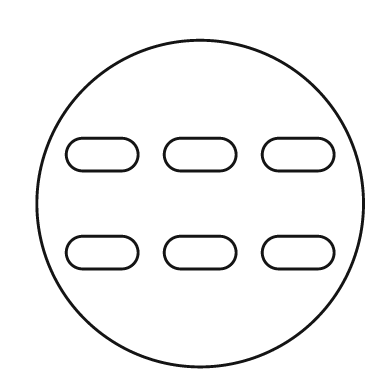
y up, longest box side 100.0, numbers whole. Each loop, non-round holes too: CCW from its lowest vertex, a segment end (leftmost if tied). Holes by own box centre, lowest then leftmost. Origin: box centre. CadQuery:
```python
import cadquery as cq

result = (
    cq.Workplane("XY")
    .moveTo(0.0, 0.0)
    .circle(50.0)
    .moveTo(-36.0, -20.0)
    .lineTo(-24.0, -20.0)
    .threePointArc((-19.0, -15.0), (-24.0, -10.0))
    .lineTo(-36.0, -10.0)
    .threePointArc((-41.0, -15.0), (-36.0, -20.0))
    .close()
    .moveTo(-6.0, -20.0)
    .lineTo(6.0, -20.0)
    .threePointArc((11.0, -15.0), (6.0, -10.0))
    .lineTo(-6.0, -10.0)
    .threePointArc((-11.0, -15.0), (-6.0, -20.0))
    .close()
    .moveTo(24.0, -20.0)
    .lineTo(36.0, -20.0)
    .threePointArc((41.0, -15.0), (36.0, -10.0))
    .lineTo(24.0, -10.0)
    .threePointArc((19.0, -15.0), (24.0, -20.0))
    .close()
    .moveTo(-36.0, 10.0)
    .lineTo(-24.0, 10.0)
    .threePointArc((-19.0, 15.0), (-24.0, 20.0))
    .lineTo(-36.0, 20.0)
    .threePointArc((-41.0, 15.0), (-36.0, 10.0))
    .close()
    .moveTo(-6.0, 10.0)
    .lineTo(6.0, 10.0)
    .threePointArc((11.0, 15.0), (6.0, 20.0))
    .lineTo(-6.0, 20.0)
    .threePointArc((-11.0, 15.0), (-6.0, 10.0))
    .close()
    .moveTo(24.0, 10.0)
    .lineTo(36.0, 10.0)
    .threePointArc((41.0, 15.0), (36.0, 20.0))
    .lineTo(24.0, 20.0)
    .threePointArc((19.0, 15.0), (24.0, 10.0))
    .close()
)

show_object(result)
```